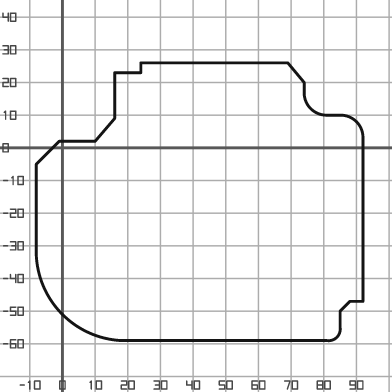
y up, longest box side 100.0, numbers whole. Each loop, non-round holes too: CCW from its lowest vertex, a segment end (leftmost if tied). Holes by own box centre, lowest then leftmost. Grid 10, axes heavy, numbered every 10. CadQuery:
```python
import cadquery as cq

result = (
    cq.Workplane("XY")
    .moveTo(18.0, -59.0)
    .lineTo(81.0, -59.0)
    .threePointArc((84.0, -58.0), (85.0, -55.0))
    .lineTo(85.0, -50.0)
    .lineTo(88.0, -47.0)
    .lineTo(92.0, -47.0)
    .lineTo(92.0, 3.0)
    .threePointArc((90.0, 8.0), (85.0, 10.0))
    .lineTo(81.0, 10.0)
    .threePointArc((76.0, 12.0), (74.0, 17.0))
    .lineTo(74.0, 20.0)
    .lineTo(69.0, 26.0)
    .lineTo(24.0, 26.0)
    .lineTo(24.0, 23.0)
    .lineTo(16.0, 23.0)
    .lineTo(16.0, 9.0)
    .lineTo(10.0, 2.0)
    .lineTo(-1.0, 2.0)
    .lineTo(-8.0, -5.0)
    .lineTo(-8.0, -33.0)
    .threePointArc((0.0, -51.0), (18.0, -59.0))
    .close()
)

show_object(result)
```